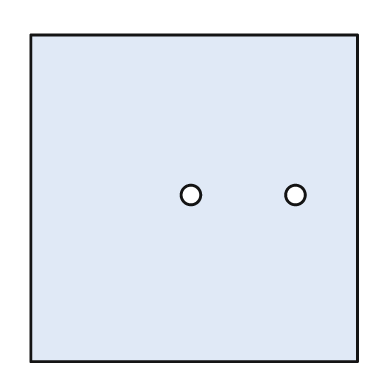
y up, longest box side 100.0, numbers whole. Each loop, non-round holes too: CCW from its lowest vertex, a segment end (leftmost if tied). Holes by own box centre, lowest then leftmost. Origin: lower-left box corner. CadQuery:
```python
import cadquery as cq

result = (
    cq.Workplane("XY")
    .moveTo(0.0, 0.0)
    .lineTo(100.0, 0.0)
    .lineTo(100.0, 100.0)
    .lineTo(0.0, 100.0)
    .close()
    .moveTo(49.0, 51.0)
    .circle(3.0)
    .moveTo(81.0, 51.0)
    .circle(3.0)
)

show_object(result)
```